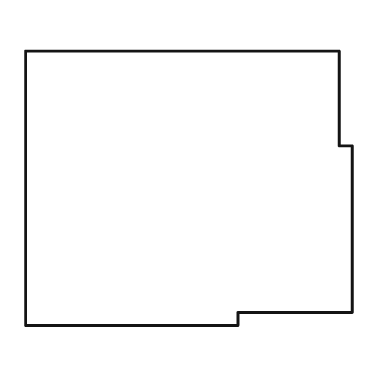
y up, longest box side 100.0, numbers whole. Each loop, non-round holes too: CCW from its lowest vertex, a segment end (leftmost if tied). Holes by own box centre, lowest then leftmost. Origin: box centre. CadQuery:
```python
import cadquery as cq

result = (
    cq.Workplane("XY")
    .moveTo(-50.0, -42.0)
    .lineTo(15.0, -42.0)
    .lineTo(15.0, -38.0)
    .lineTo(50.0, -38.0)
    .lineTo(50.0, 13.0)
    .lineTo(46.0, 13.0)
    .lineTo(46.0, 42.0)
    .lineTo(-50.0, 42.0)
    .close()
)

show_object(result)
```